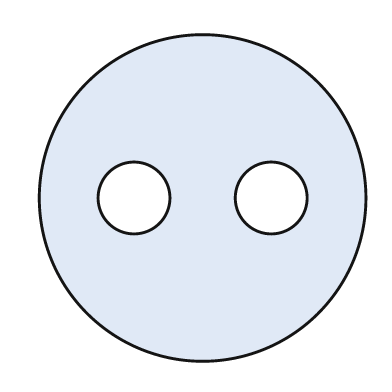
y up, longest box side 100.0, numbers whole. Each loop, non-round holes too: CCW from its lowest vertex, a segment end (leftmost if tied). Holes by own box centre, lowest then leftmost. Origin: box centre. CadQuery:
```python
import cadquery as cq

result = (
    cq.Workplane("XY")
    .moveTo(0.0, 0.0)
    .circle(50.0)
    .moveTo(-21.0, 0.0)
    .circle(11.0)
    .moveTo(21.0, 0.0)
    .circle(11.0)
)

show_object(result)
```